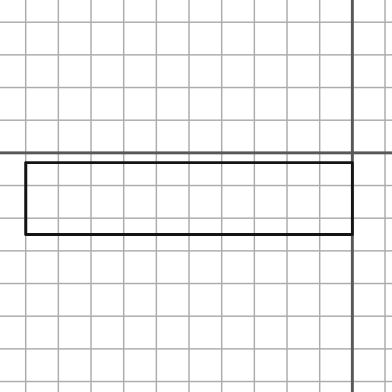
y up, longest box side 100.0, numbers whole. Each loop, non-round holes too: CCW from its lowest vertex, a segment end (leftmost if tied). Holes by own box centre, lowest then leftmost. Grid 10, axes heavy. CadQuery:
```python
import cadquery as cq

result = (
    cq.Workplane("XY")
    .moveTo(-100.0, -25.0)
    .lineTo(0.0, -25.0)
    .lineTo(0.0, -3.0)
    .lineTo(-100.0, -3.0)
    .close()
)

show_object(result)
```